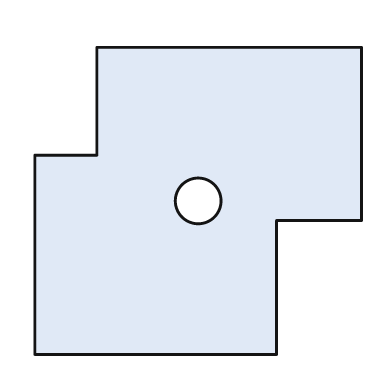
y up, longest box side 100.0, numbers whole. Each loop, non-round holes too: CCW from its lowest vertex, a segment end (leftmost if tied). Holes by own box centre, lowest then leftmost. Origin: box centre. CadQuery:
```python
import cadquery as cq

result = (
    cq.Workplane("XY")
    .moveTo(-50.0, -47.0)
    .lineTo(24.0, -47.0)
    .lineTo(24.0, -6.0)
    .lineTo(50.0, -6.0)
    .lineTo(50.0, 47.0)
    .lineTo(-31.0, 47.0)
    .lineTo(-31.0, 14.0)
    .lineTo(-50.0, 14.0)
    .close()
    .moveTo(0.0, 0.0)
    .circle(7.0)
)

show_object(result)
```